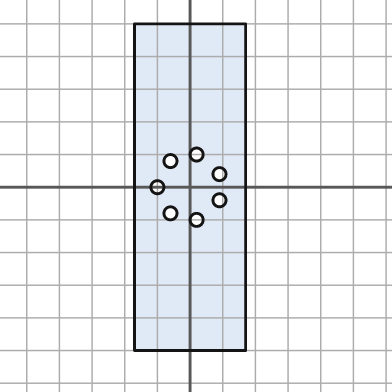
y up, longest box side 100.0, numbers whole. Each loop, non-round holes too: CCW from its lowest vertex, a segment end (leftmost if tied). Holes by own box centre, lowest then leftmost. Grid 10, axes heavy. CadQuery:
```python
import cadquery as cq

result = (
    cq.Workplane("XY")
    .moveTo(-17.0, -50.0)
    .lineTo(17.0, -50.0)
    .lineTo(17.0, 50.0)
    .lineTo(-17.0, 50.0)
    .close()
    .moveTo(2.0, -10.0)
    .circle(2.0)
    .moveTo(-6.0, -8.0)
    .circle(2.0)
    .moveTo(9.0, -4.0)
    .circle(2.0)
    .moveTo(-10.0, 0.0)
    .circle(2.0)
    .moveTo(9.0, 4.0)
    .circle(2.0)
    .moveTo(-6.0, 8.0)
    .circle(2.0)
    .moveTo(2.0, 10.0)
    .circle(2.0)
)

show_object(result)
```